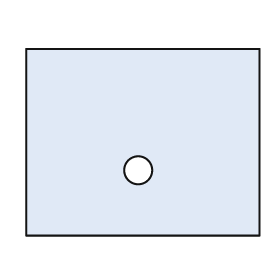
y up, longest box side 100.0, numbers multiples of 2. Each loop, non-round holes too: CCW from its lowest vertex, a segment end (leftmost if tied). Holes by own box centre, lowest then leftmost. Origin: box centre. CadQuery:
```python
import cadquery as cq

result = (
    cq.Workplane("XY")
    .moveTo(-50.0, -40.0)
    .lineTo(50.0, -40.0)
    .lineTo(50.0, 40.0)
    .lineTo(-50.0, 40.0)
    .close()
    .moveTo(-2.0, -12.0)
    .circle(6.0)
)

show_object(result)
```